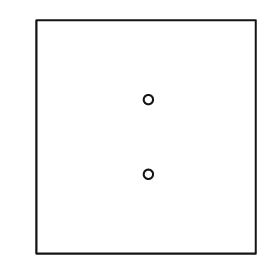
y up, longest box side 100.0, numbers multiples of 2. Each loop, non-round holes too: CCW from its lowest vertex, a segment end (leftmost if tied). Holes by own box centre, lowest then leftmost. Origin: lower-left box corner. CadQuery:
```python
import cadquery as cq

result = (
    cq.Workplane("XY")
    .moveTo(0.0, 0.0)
    .lineTo(94.0, 0.0)
    .lineTo(94.0, 100.0)
    .lineTo(0.0, 100.0)
    .close()
    .moveTo(48.0, 34.0)
    .circle(2.0)
    .moveTo(48.0, 66.0)
    .circle(2.0)
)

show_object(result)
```